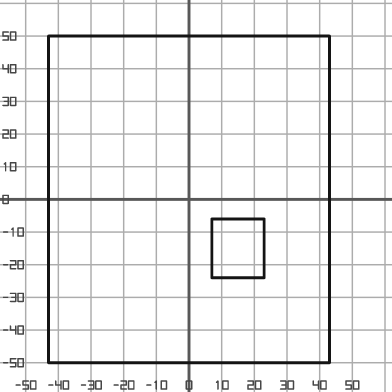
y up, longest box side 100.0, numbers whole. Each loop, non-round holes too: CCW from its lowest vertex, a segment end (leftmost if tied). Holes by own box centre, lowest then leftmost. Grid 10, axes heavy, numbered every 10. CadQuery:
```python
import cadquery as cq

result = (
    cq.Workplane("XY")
    .moveTo(-43.0, -50.0)
    .lineTo(43.0, -50.0)
    .lineTo(43.0, 50.0)
    .lineTo(-43.0, 50.0)
    .close()
    .moveTo(7.0, -24.0)
    .lineTo(23.0, -24.0)
    .lineTo(23.0, -6.0)
    .lineTo(7.0, -6.0)
    .close()
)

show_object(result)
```